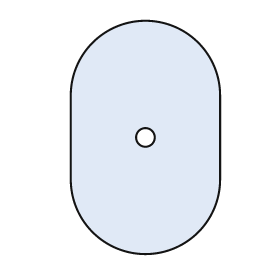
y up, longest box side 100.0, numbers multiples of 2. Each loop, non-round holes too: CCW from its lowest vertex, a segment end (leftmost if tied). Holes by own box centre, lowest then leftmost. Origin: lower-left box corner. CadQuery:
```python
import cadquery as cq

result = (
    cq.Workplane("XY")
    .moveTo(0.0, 32.0)
    .threePointArc((32.0, 0.0), (64.0, 32.0))
    .lineTo(64.0, 68.0)
    .threePointArc((32.0, 100.0), (0.0, 68.0))
    .close()
    .moveTo(32.0, 50.0)
    .circle(4.0)
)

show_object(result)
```